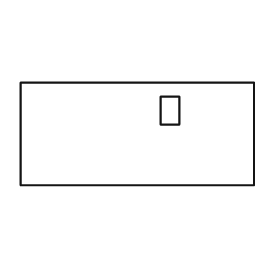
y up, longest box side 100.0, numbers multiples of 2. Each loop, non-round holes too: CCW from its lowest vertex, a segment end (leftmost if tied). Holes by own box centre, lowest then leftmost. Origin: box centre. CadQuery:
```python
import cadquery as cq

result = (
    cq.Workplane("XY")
    .moveTo(-50.0, -22.0)
    .lineTo(50.0, -22.0)
    .lineTo(50.0, 22.0)
    .lineTo(-50.0, 22.0)
    .close()
    .moveTo(10.0, 4.0)
    .lineTo(18.0, 4.0)
    .lineTo(18.0, 16.0)
    .lineTo(10.0, 16.0)
    .close()
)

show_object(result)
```